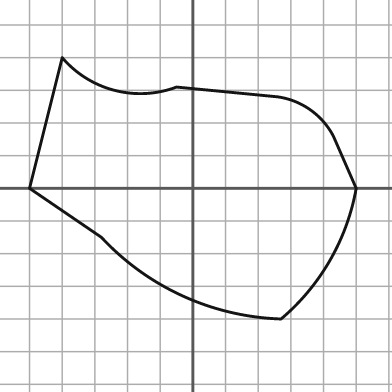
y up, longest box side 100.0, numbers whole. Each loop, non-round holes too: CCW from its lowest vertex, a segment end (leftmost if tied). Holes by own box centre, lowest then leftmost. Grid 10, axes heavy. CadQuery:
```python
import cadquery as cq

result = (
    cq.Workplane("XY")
    .moveTo(27.0, -40.0)
    .threePointArc((42.0, -22.0), (50.0, 0.0))
    .lineTo(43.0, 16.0)
    .threePointArc((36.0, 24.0), (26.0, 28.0))
    .lineTo(-5.0, 31.0)
    .threePointArc((-24.0, 30.0), (-40.0, 40.0))
    .lineTo(-50.0, 0.0)
    .lineTo(-28.0, -15.0)
    .threePointArc((-3.0, -33.0), (27.0, -40.0))
    .close()
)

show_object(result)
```